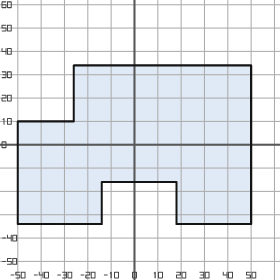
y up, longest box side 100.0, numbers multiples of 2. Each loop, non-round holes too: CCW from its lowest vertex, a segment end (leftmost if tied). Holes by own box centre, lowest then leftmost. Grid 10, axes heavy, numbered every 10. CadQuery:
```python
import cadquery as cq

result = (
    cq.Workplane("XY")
    .moveTo(-50.0, -34.0)
    .lineTo(-14.0, -34.0)
    .lineTo(-14.0, -16.0)
    .lineTo(18.0, -16.0)
    .lineTo(18.0, -34.0)
    .lineTo(50.0, -34.0)
    .lineTo(50.0, 34.0)
    .lineTo(-26.0, 34.0)
    .lineTo(-26.0, 10.0)
    .lineTo(-50.0, 10.0)
    .close()
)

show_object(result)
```